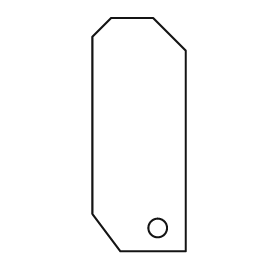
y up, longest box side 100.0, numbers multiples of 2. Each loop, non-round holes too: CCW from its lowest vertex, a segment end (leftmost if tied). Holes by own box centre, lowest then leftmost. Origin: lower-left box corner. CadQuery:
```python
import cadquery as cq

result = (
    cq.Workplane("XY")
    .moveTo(12.0, 0.0)
    .lineTo(40.0, 0.0)
    .lineTo(40.0, 86.0)
    .lineTo(26.0, 100.0)
    .lineTo(8.0, 100.0)
    .lineTo(0.0, 92.0)
    .lineTo(0.0, 16.0)
    .close()
    .moveTo(28.0, 10.0)
    .circle(4.0)
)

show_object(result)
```